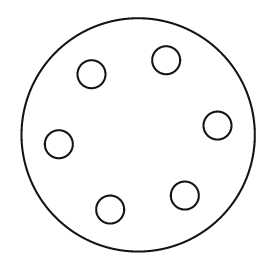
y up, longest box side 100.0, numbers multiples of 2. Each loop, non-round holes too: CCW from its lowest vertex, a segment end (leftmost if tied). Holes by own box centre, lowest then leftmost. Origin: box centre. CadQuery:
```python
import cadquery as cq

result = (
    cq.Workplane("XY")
    .moveTo(0.0, 0.0)
    .circle(50.0)
    .moveTo(-12.0, -32.0)
    .circle(6.0)
    .moveTo(20.0, -26.0)
    .circle(6.0)
    .moveTo(-34.0, -4.0)
    .circle(6.0)
    .moveTo(34.0, 4.0)
    .circle(6.0)
    .moveTo(-20.0, 26.0)
    .circle(6.0)
    .moveTo(12.0, 32.0)
    .circle(6.0)
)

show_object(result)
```